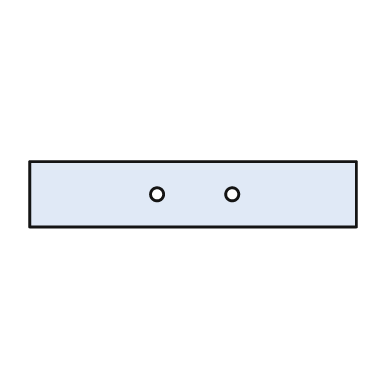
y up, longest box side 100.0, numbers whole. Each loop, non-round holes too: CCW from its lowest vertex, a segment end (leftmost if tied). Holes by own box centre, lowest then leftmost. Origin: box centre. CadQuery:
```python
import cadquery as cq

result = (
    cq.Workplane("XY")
    .moveTo(-50.0, -10.0)
    .lineTo(50.0, -10.0)
    .lineTo(50.0, 10.0)
    .lineTo(-50.0, 10.0)
    .close()
    .moveTo(-11.0, 0.0)
    .circle(2.0)
    .moveTo(12.0, 0.0)
    .circle(2.0)
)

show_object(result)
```